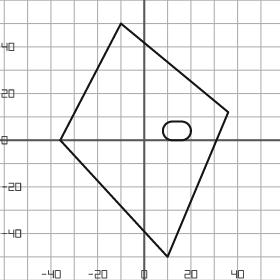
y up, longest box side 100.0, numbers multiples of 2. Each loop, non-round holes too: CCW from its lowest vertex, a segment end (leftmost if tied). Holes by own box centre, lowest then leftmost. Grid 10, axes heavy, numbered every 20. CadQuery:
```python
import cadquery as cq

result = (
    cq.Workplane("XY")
    .moveTo(10.0, -50.0)
    .lineTo(36.0, 12.0)
    .lineTo(-10.0, 50.0)
    .lineTo(-36.0, 0.0)
    .close()
    .moveTo(12.0, 0.0)
    .lineTo(16.0, 0.0)
    .threePointArc((20.0, 4.0), (16.0, 8.0))
    .lineTo(12.0, 8.0)
    .threePointArc((8.0, 4.0), (12.0, 0.0))
    .close()
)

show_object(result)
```